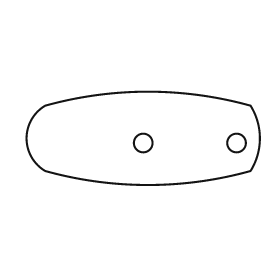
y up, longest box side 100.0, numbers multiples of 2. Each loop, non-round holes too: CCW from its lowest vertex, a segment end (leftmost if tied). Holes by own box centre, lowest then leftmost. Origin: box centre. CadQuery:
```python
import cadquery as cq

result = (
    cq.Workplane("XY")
    .moveTo(-42.0, -14.0)
    .threePointArc((2.0, -20.0), (46.0, -14.0))
    .threePointArc((50.0, 0.0), (46.0, 14.0))
    .threePointArc((2.0, 20.0), (-42.0, 14.0))
    .threePointArc((-50.0, 0.0), (-42.0, -14.0))
    .close()
    .moveTo(0.0, -2.0)
    .circle(4.0)
    .moveTo(40.0, -2.0)
    .circle(4.0)
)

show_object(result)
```